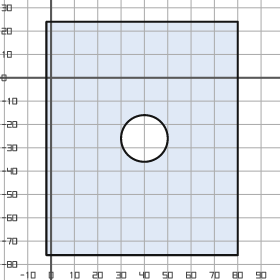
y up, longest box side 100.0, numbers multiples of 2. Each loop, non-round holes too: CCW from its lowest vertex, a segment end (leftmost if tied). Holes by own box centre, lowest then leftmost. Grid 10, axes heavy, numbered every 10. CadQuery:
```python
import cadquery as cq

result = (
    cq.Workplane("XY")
    .moveTo(-2.0, -76.0)
    .lineTo(80.0, -76.0)
    .lineTo(80.0, 24.0)
    .lineTo(-2.0, 24.0)
    .close()
    .moveTo(40.0, -26.0)
    .circle(10.0)
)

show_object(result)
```